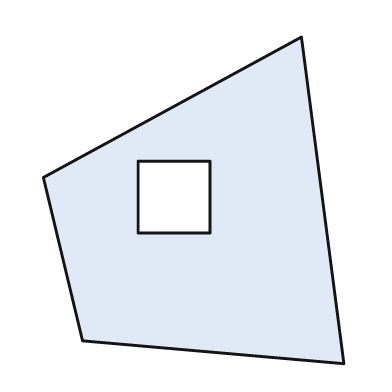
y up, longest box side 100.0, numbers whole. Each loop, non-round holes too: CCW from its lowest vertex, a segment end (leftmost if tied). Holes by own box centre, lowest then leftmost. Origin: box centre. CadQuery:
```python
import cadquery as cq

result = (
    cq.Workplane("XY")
    .moveTo(46.0, -50.0)
    .lineTo(33.0, 50.0)
    .lineTo(-46.0, 7.0)
    .lineTo(-34.0, -43.0)
    .close()
    .moveTo(-17.0, -10.0)
    .lineTo(5.0, -10.0)
    .lineTo(5.0, 12.0)
    .lineTo(-17.0, 12.0)
    .close()
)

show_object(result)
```